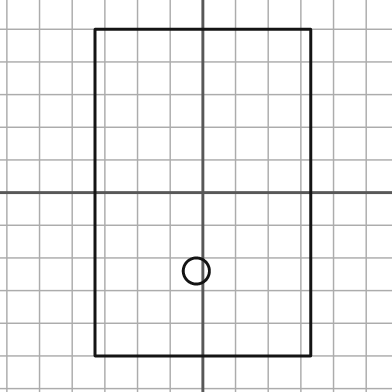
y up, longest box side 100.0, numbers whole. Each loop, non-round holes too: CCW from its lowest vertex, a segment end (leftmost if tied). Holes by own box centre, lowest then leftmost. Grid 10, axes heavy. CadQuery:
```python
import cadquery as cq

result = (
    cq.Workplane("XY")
    .moveTo(-33.0, -50.0)
    .lineTo(33.0, -50.0)
    .lineTo(33.0, 50.0)
    .lineTo(-33.0, 50.0)
    .close()
    .moveTo(-2.0, -24.0)
    .circle(4.0)
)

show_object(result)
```